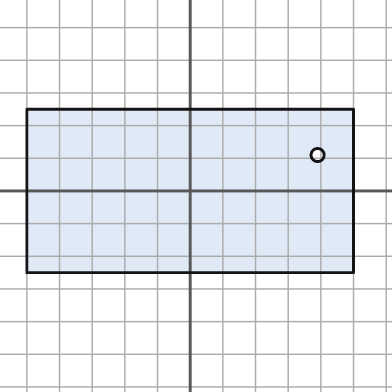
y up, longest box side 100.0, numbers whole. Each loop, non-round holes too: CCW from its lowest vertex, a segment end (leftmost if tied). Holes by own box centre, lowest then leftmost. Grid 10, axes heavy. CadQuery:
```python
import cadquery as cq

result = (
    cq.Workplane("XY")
    .moveTo(-50.0, -25.0)
    .lineTo(50.0, -25.0)
    .lineTo(50.0, 25.0)
    .lineTo(-50.0, 25.0)
    .close()
    .moveTo(39.0, 11.0)
    .circle(2.0)
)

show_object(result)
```